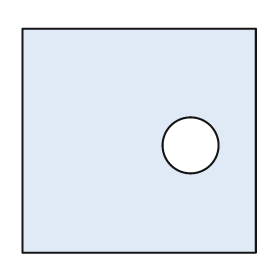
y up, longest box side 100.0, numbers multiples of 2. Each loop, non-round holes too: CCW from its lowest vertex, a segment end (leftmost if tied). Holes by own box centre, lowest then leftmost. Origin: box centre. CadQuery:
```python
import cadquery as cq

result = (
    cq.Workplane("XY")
    .moveTo(-50.0, -48.0)
    .lineTo(50.0, -48.0)
    .lineTo(50.0, 48.0)
    .lineTo(-50.0, 48.0)
    .close()
    .moveTo(22.0, -2.0)
    .circle(12.0)
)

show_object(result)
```